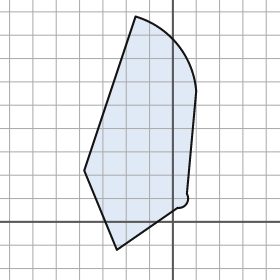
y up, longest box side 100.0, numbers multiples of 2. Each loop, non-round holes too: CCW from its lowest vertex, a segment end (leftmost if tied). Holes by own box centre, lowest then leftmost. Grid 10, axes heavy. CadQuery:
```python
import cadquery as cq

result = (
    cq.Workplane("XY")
    .moveTo(-24.0, -12.0)
    .lineTo(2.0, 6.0)
    .threePointArc((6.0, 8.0), (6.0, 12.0))
    .lineTo(10.0, 56.0)
    .threePointArc((2.0, 76.0), (-16.0, 88.0))
    .lineTo(-38.0, 22.0)
    .close()
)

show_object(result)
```